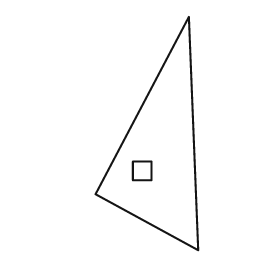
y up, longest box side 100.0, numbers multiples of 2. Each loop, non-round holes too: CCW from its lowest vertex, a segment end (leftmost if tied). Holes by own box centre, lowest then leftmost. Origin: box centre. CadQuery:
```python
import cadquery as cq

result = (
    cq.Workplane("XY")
    .moveTo(22.0, -50.0)
    .lineTo(18.0, 50.0)
    .lineTo(-22.0, -26.0)
    .close()
    .moveTo(-6.0, -20.0)
    .lineTo(2.0, -20.0)
    .lineTo(2.0, -12.0)
    .lineTo(-6.0, -12.0)
    .close()
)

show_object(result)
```